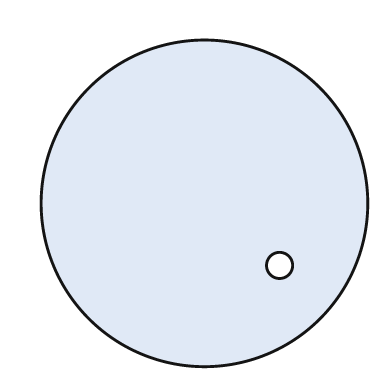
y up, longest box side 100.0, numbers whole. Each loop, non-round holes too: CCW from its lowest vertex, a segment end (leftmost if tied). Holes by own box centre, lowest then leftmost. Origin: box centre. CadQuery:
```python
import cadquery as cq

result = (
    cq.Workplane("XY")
    .moveTo(0.0, 0.0)
    .circle(50.0)
    .moveTo(23.0, -19.0)
    .circle(4.0)
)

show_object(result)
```